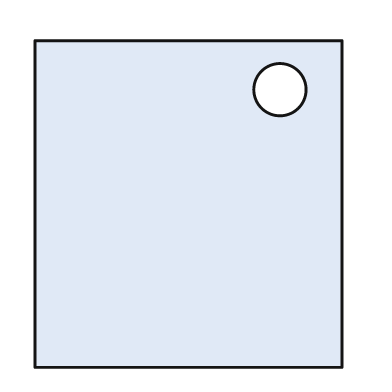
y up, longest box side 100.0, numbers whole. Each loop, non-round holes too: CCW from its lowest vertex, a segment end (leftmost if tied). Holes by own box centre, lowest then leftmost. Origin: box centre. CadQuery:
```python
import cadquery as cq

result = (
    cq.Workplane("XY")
    .moveTo(-47.0, -50.0)
    .lineTo(47.0, -50.0)
    .lineTo(47.0, 50.0)
    .lineTo(-47.0, 50.0)
    .close()
    .moveTo(28.0, 35.0)
    .circle(8.0)
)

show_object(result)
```